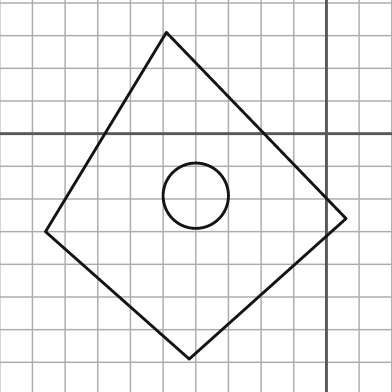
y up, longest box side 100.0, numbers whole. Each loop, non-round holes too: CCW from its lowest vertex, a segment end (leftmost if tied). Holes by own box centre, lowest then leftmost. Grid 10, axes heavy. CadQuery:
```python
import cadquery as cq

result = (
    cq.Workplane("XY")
    .moveTo(-42.0, -69.0)
    .lineTo(6.0, -26.0)
    .lineTo(-49.0, 31.0)
    .lineTo(-86.0, -30.0)
    .close()
    .moveTo(-40.0, -19.0)
    .circle(10.0)
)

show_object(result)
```